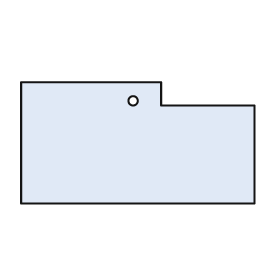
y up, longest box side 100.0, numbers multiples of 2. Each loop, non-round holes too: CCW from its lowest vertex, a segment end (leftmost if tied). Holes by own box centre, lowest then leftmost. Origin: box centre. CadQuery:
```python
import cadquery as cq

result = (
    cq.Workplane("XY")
    .moveTo(-50.0, -26.0)
    .lineTo(50.0, -26.0)
    .lineTo(50.0, 16.0)
    .lineTo(10.0, 16.0)
    .lineTo(10.0, 26.0)
    .lineTo(-50.0, 26.0)
    .close()
    .moveTo(-2.0, 18.0)
    .circle(2.0)
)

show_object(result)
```